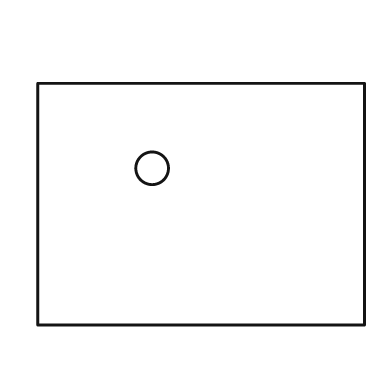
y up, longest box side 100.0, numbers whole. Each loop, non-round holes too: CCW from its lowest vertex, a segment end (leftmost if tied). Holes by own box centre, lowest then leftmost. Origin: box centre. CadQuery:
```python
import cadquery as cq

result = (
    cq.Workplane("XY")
    .moveTo(-50.0, -37.0)
    .lineTo(50.0, -37.0)
    .lineTo(50.0, 37.0)
    .lineTo(-50.0, 37.0)
    .close()
    .moveTo(-15.0, 11.0)
    .circle(5.0)
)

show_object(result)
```